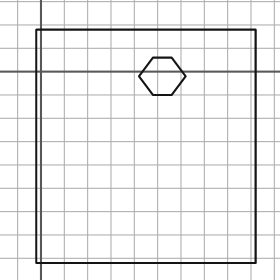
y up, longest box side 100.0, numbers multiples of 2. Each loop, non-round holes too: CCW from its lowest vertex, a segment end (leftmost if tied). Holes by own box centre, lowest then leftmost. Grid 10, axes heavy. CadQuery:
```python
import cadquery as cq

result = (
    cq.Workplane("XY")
    .moveTo(-2.0, -82.0)
    .lineTo(92.0, -82.0)
    .lineTo(92.0, 18.0)
    .lineTo(-2.0, 18.0)
    .close()
    .moveTo(48.0, -10.0)
    .lineTo(56.0, -10.0)
    .lineTo(62.0, -2.0)
    .lineTo(56.0, 6.0)
    .lineTo(48.0, 6.0)
    .lineTo(42.0, -2.0)
    .close()
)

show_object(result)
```